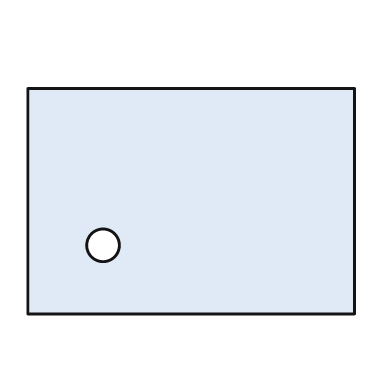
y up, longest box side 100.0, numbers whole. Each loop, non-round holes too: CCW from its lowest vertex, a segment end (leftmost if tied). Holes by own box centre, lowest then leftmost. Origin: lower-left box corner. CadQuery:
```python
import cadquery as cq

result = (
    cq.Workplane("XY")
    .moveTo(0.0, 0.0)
    .lineTo(100.0, 0.0)
    .lineTo(100.0, 69.0)
    .lineTo(0.0, 69.0)
    .close()
    .moveTo(23.0, 21.0)
    .circle(5.0)
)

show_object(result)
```